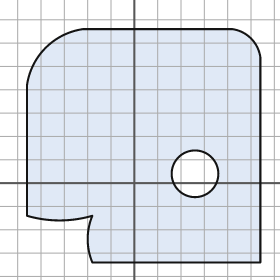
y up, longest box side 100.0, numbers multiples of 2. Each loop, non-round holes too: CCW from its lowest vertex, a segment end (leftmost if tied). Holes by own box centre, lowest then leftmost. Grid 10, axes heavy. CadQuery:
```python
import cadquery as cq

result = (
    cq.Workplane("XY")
    .moveTo(-18.0, -34.0)
    .lineTo(54.0, -34.0)
    .lineTo(54.0, 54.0)
    .threePointArc((50.0, 62.0), (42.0, 66.0))
    .lineTo(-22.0, 66.0)
    .threePointArc((-38.0, 58.0), (-46.0, 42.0))
    .lineTo(-46.0, -14.0)
    .threePointArc((-32.0, -16.0), (-18.0, -14.0))
    .threePointArc((-20.0, -24.0), (-18.0, -34.0))
    .close()
    .moveTo(26.0, 4.0)
    .circle(10.0)
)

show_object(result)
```